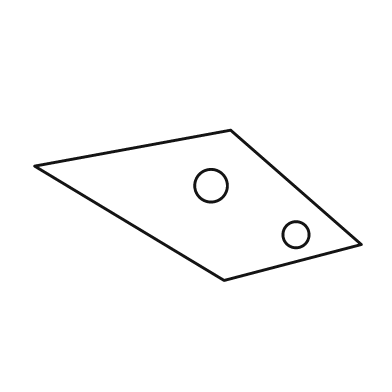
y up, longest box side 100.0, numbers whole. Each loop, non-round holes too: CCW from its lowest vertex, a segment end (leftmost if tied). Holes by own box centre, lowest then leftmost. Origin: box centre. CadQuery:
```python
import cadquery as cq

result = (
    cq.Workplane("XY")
    .moveTo(8.0, -23.0)
    .lineTo(50.0, -12.0)
    .lineTo(10.0, 23.0)
    .lineTo(-50.0, 12.0)
    .close()
    .moveTo(30.0, -9.0)
    .circle(4.0)
    .moveTo(4.0, 6.0)
    .circle(5.0)
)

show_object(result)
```